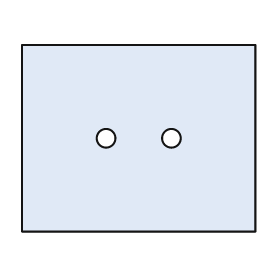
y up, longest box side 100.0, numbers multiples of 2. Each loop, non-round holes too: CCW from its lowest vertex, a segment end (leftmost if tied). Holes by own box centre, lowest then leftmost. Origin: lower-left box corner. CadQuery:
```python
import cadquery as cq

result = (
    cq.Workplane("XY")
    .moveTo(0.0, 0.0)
    .lineTo(100.0, 0.0)
    .lineTo(100.0, 80.0)
    .lineTo(0.0, 80.0)
    .close()
    .moveTo(36.0, 40.0)
    .circle(4.0)
    .moveTo(64.0, 40.0)
    .circle(4.0)
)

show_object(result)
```